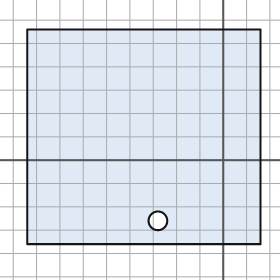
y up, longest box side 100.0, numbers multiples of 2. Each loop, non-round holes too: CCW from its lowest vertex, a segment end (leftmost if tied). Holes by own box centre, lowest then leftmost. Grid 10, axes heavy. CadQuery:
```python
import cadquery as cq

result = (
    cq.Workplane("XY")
    .moveTo(-84.0, -36.0)
    .lineTo(16.0, -36.0)
    .lineTo(16.0, 56.0)
    .lineTo(-84.0, 56.0)
    .close()
    .moveTo(-28.0, -26.0)
    .circle(4.0)
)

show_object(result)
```